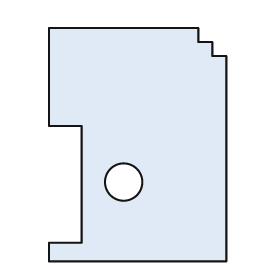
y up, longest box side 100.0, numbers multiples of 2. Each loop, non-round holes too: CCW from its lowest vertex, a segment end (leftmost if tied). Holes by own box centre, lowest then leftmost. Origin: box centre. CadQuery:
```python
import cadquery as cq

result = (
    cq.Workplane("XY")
    .moveTo(-38.0, -50.0)
    .lineTo(38.0, -50.0)
    .lineTo(38.0, 38.0)
    .lineTo(32.0, 38.0)
    .lineTo(32.0, 44.0)
    .lineTo(26.0, 44.0)
    .lineTo(26.0, 50.0)
    .lineTo(-38.0, 50.0)
    .lineTo(-38.0, 8.0)
    .lineTo(-24.0, 8.0)
    .lineTo(-24.0, -42.0)
    .lineTo(-38.0, -42.0)
    .close()
    .moveTo(-6.0, -16.0)
    .circle(8.0)
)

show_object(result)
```